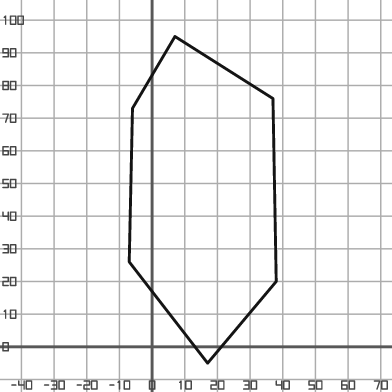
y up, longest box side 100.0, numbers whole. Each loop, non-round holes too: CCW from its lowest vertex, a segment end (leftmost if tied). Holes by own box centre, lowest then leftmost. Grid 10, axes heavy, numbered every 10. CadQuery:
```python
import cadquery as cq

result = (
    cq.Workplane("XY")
    .moveTo(17.0, -5.0)
    .lineTo(38.0, 20.0)
    .lineTo(37.0, 76.0)
    .lineTo(7.0, 95.0)
    .lineTo(-6.0, 73.0)
    .lineTo(-7.0, 26.0)
    .close()
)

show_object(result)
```